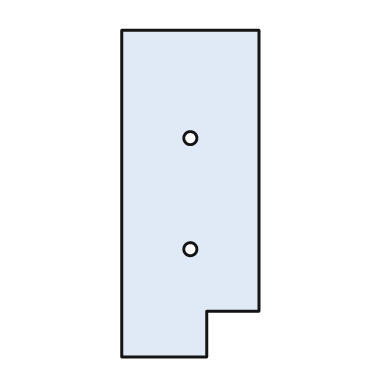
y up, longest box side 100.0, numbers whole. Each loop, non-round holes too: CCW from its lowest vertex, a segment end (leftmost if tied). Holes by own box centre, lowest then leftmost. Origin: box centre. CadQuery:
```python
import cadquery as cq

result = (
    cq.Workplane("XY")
    .moveTo(-21.0, -50.0)
    .lineTo(5.0, -50.0)
    .lineTo(5.0, -36.0)
    .lineTo(21.0, -36.0)
    .lineTo(21.0, 50.0)
    .lineTo(-21.0, 50.0)
    .close()
    .moveTo(0.0, -17.0)
    .circle(2.0)
    .moveTo(0.0, 17.0)
    .circle(2.0)
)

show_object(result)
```